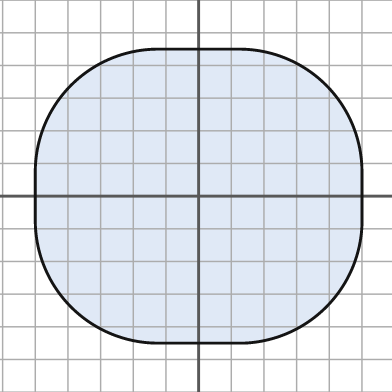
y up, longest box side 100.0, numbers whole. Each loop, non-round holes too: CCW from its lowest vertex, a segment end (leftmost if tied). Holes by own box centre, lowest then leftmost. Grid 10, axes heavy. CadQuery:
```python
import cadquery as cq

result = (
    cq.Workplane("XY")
    .moveTo(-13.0, -45.0)
    .lineTo(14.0, -45.0)
    .threePointArc((39.0, -34.0), (50.0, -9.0))
    .lineTo(50.0, 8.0)
    .threePointArc((39.0, 34.0), (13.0, 45.0))
    .lineTo(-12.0, 45.0)
    .threePointArc((-39.0, 34.0), (-50.0, 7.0))
    .lineTo(-50.0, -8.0)
    .threePointArc((-39.0, -34.0), (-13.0, -45.0))
    .close()
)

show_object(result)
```